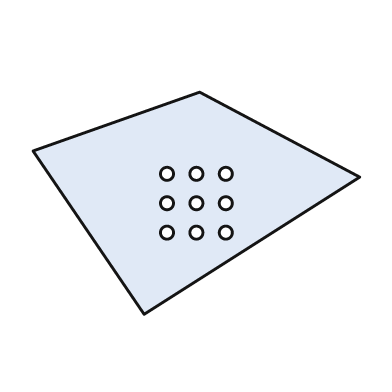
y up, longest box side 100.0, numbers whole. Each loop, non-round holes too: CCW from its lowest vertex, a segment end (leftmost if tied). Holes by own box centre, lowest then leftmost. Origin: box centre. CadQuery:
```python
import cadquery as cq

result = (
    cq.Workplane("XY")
    .moveTo(-16.0, -34.0)
    .lineTo(50.0, 8.0)
    .lineTo(1.0, 34.0)
    .lineTo(-50.0, 16.0)
    .close()
    .moveTo(-9.0, -9.0)
    .circle(2.0)
    .moveTo(0.0, -9.0)
    .circle(2.0)
    .moveTo(9.0, -9.0)
    .circle(2.0)
    .moveTo(-9.0, 0.0)
    .circle(2.0)
    .moveTo(0.0, 0.0)
    .circle(2.0)
    .moveTo(9.0, 0.0)
    .circle(2.0)
    .moveTo(-9.0, 9.0)
    .circle(2.0)
    .moveTo(0.0, 9.0)
    .circle(2.0)
    .moveTo(9.0, 9.0)
    .circle(2.0)
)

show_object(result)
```